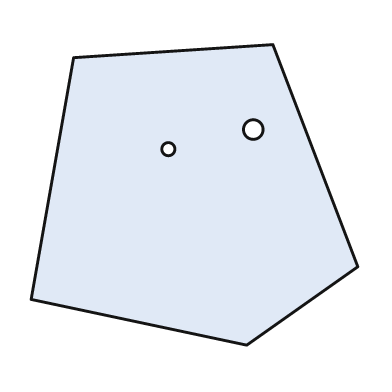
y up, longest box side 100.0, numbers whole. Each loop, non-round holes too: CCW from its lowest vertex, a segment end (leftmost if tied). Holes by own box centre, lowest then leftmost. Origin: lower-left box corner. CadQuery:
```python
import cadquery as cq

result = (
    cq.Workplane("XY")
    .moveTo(66.0, 0.0)
    .lineTo(100.0, 24.0)
    .lineTo(74.0, 92.0)
    .lineTo(13.0, 88.0)
    .lineTo(0.0, 14.0)
    .close()
    .moveTo(42.0, 60.0)
    .circle(2.0)
    .moveTo(68.0, 66.0)
    .circle(3.0)
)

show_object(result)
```